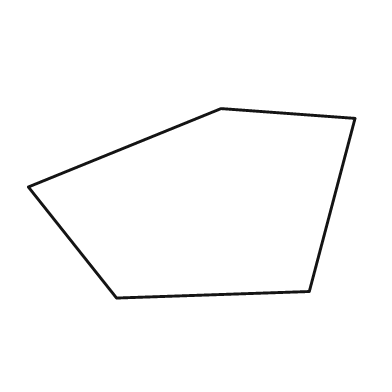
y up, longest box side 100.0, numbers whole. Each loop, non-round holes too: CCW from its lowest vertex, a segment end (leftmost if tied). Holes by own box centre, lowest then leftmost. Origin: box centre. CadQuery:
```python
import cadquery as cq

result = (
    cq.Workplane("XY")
    .moveTo(-23.0, -29.0)
    .lineTo(36.0, -27.0)
    .lineTo(50.0, 26.0)
    .lineTo(9.0, 29.0)
    .lineTo(-50.0, 5.0)
    .close()
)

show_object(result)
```